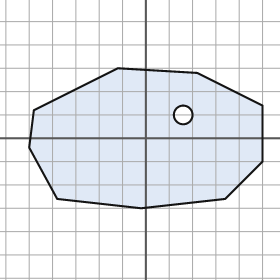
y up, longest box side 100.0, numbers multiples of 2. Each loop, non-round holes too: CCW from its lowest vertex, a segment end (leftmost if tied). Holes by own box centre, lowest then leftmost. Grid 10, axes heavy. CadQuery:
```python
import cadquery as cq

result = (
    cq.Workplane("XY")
    .moveTo(-2.0, -30.0)
    .lineTo(34.0, -26.0)
    .lineTo(50.0, -10.0)
    .lineTo(50.0, 14.0)
    .lineTo(22.0, 28.0)
    .lineTo(-12.0, 30.0)
    .lineTo(-48.0, 12.0)
    .lineTo(-50.0, -4.0)
    .lineTo(-38.0, -26.0)
    .close()
    .moveTo(16.0, 10.0)
    .circle(4.0)
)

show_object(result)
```